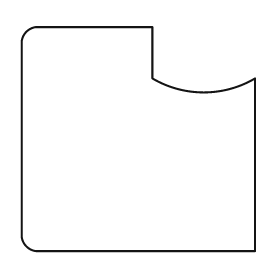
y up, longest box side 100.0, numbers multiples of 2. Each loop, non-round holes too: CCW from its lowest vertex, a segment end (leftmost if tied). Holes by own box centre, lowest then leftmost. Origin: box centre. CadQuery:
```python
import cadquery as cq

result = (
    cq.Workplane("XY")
    .moveTo(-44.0, -48.0)
    .lineTo(50.0, -48.0)
    .lineTo(50.0, 26.0)
    .threePointArc((28.0, 20.0), (6.0, 26.0))
    .lineTo(6.0, 48.0)
    .lineTo(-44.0, 48.0)
    .threePointArc((-48.0, 46.0), (-50.0, 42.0))
    .lineTo(-50.0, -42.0)
    .threePointArc((-48.0, -46.0), (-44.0, -48.0))
    .close()
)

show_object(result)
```